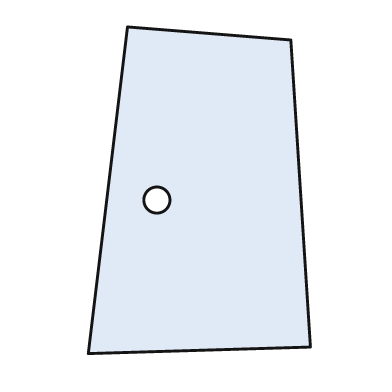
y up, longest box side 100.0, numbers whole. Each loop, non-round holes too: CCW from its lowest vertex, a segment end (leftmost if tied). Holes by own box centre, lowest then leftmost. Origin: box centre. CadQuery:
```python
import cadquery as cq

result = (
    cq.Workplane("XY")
    .moveTo(-34.0, -50.0)
    .lineTo(34.0, -48.0)
    .lineTo(28.0, 46.0)
    .lineTo(-22.0, 50.0)
    .close()
    .moveTo(-13.0, -3.0)
    .circle(4.0)
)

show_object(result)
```